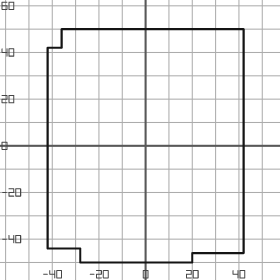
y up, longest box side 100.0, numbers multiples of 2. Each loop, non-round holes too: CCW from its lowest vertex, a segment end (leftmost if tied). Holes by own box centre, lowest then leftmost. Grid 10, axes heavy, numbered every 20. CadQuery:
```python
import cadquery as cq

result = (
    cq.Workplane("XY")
    .moveTo(-28.0, -50.0)
    .lineTo(20.0, -50.0)
    .lineTo(20.0, -46.0)
    .lineTo(42.0, -46.0)
    .lineTo(42.0, 50.0)
    .lineTo(-36.0, 50.0)
    .lineTo(-36.0, 42.0)
    .lineTo(-42.0, 42.0)
    .lineTo(-42.0, -44.0)
    .lineTo(-28.0, -44.0)
    .close()
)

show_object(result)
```